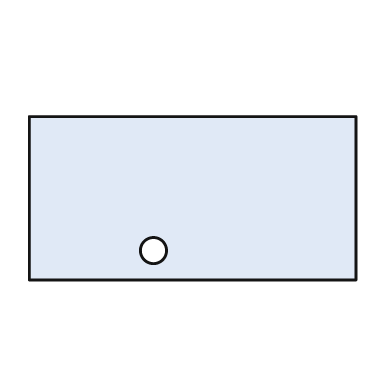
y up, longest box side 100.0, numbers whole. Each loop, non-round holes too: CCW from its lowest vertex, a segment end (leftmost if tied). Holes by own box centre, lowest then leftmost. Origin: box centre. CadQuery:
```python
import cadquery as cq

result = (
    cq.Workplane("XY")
    .moveTo(-50.0, -25.0)
    .lineTo(50.0, -25.0)
    .lineTo(50.0, 25.0)
    .lineTo(-50.0, 25.0)
    .close()
    .moveTo(-12.0, -16.0)
    .circle(4.0)
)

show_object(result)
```